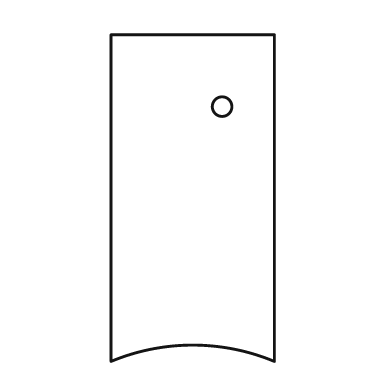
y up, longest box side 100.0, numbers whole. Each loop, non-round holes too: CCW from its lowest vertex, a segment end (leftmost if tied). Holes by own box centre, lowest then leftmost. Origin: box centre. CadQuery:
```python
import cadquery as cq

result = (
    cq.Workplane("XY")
    .moveTo(-25.0, -50.0)
    .threePointArc((0.0, -45.0), (25.0, -50.0))
    .lineTo(25.0, 50.0)
    .lineTo(-25.0, 50.0)
    .close()
    .moveTo(9.0, 28.0)
    .circle(3.0)
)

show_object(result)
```